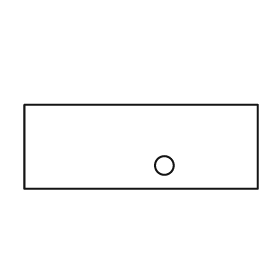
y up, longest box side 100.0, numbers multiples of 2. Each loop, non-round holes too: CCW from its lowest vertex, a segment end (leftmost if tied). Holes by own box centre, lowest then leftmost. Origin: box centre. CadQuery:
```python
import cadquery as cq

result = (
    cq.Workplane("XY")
    .moveTo(-50.0, -18.0)
    .lineTo(50.0, -18.0)
    .lineTo(50.0, 18.0)
    .lineTo(-50.0, 18.0)
    .close()
    .moveTo(10.0, -8.0)
    .circle(4.0)
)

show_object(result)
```